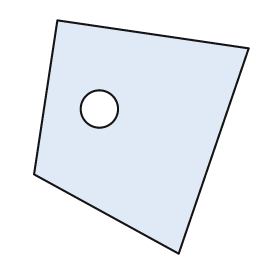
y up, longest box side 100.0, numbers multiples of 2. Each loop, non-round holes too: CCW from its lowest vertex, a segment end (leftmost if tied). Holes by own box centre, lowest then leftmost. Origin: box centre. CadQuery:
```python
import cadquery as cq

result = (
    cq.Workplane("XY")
    .moveTo(16.0, -50.0)
    .lineTo(46.0, 38.0)
    .lineTo(-36.0, 50.0)
    .lineTo(-46.0, -16.0)
    .close()
    .moveTo(-18.0, 12.0)
    .circle(8.0)
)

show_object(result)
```